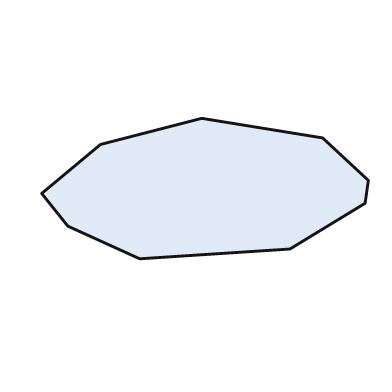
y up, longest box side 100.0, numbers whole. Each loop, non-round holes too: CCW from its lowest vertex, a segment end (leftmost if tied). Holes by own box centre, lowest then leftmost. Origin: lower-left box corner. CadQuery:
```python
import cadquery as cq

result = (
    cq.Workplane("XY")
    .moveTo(30.0, 0.0)
    .lineTo(76.0, 3.0)
    .lineTo(99.0, 17.0)
    .lineTo(100.0, 24.0)
    .lineTo(86.0, 37.0)
    .lineTo(49.0, 43.0)
    .lineTo(18.0, 35.0)
    .lineTo(0.0, 20.0)
    .lineTo(8.0, 10.0)
    .close()
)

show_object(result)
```